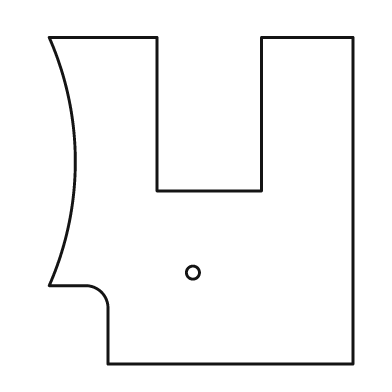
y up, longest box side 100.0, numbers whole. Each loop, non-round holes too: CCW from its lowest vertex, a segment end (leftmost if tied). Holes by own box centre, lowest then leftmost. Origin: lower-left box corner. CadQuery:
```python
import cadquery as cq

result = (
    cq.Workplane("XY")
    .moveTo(18.0, 0.0)
    .lineTo(93.0, 0.0)
    .lineTo(93.0, 100.0)
    .lineTo(65.0, 100.0)
    .lineTo(65.0, 53.0)
    .lineTo(33.0, 53.0)
    .lineTo(33.0, 100.0)
    .lineTo(0.0, 100.0)
    .threePointArc((8.0, 62.0), (0.0, 24.0))
    .lineTo(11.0, 24.0)
    .threePointArc((16.0, 22.0), (18.0, 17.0))
    .close()
    .moveTo(44.0, 28.0)
    .circle(2.0)
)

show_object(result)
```